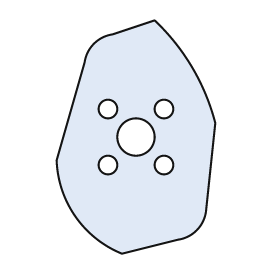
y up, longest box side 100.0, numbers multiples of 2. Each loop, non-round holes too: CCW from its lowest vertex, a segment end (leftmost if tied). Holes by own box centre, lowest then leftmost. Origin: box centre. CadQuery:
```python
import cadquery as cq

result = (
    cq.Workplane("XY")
    .moveTo(-6.0, -50.0)
    .lineTo(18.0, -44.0)
    .threePointArc((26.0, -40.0), (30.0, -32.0))
    .lineTo(34.0, 6.0)
    .threePointArc((24.0, 30.0), (8.0, 50.0))
    .lineTo(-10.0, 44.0)
    .threePointArc((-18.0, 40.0), (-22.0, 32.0))
    .lineTo(-34.0, -10.0)
    .threePointArc((-26.0, -34.0), (-6.0, -50.0))
    .close()
    .moveTo(-12.0, -12.0)
    .circle(4.0)
    .moveTo(12.0, -12.0)
    .circle(4.0)
    .moveTo(0.0, 0.0)
    .circle(8.0)
    .moveTo(-12.0, 12.0)
    .circle(4.0)
    .moveTo(12.0, 12.0)
    .circle(4.0)
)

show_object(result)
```